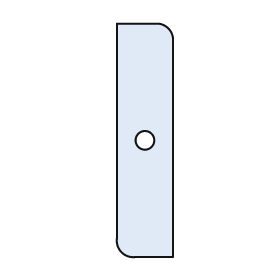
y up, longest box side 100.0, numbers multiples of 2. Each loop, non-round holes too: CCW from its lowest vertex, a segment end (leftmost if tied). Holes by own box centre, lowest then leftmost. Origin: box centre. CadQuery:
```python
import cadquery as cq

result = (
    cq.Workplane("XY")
    .moveTo(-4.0, -50.0)
    .lineTo(12.0, -50.0)
    .lineTo(12.0, 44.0)
    .threePointArc((10.0, 48.0), (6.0, 50.0))
    .lineTo(-12.0, 50.0)
    .lineTo(-12.0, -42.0)
    .threePointArc((-10.0, -48.0), (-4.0, -50.0))
    .close()
    .moveTo(0.0, 0.0)
    .circle(4.0)
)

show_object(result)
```